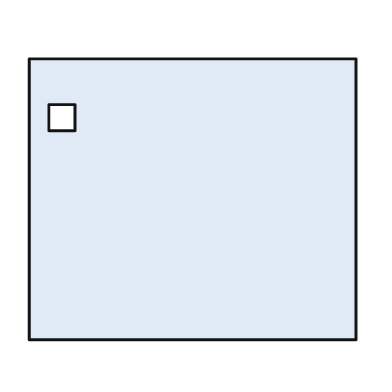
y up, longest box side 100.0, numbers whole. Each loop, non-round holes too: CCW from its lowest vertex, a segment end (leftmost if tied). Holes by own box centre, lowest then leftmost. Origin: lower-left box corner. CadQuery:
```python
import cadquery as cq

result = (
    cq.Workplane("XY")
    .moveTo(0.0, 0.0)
    .lineTo(100.0, 0.0)
    .lineTo(100.0, 86.0)
    .lineTo(0.0, 86.0)
    .close()
    .moveTo(6.0, 64.0)
    .lineTo(14.0, 64.0)
    .lineTo(14.0, 72.0)
    .lineTo(6.0, 72.0)
    .close()
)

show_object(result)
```